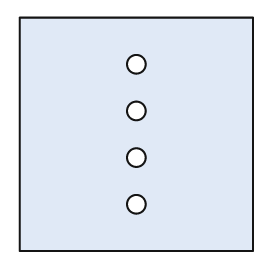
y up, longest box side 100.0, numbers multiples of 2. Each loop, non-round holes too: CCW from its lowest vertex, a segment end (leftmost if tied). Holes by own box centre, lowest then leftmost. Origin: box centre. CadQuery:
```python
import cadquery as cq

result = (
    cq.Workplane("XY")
    .moveTo(-50.0, -50.0)
    .lineTo(50.0, -50.0)
    .lineTo(50.0, 50.0)
    .lineTo(-50.0, 50.0)
    .close()
    .moveTo(0.0, -30.0)
    .circle(4.0)
    .moveTo(0.0, -10.0)
    .circle(4.0)
    .moveTo(0.0, 10.0)
    .circle(4.0)
    .moveTo(0.0, 30.0)
    .circle(4.0)
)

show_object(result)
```